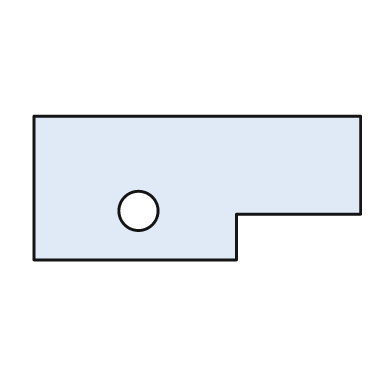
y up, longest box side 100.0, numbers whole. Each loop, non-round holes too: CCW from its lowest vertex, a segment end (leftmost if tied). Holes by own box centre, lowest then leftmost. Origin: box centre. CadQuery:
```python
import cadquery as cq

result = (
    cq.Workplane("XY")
    .moveTo(-50.0, -22.0)
    .lineTo(12.0, -22.0)
    .lineTo(12.0, -8.0)
    .lineTo(50.0, -8.0)
    .lineTo(50.0, 22.0)
    .lineTo(-50.0, 22.0)
    .close()
    .moveTo(-18.0, -7.0)
    .circle(6.0)
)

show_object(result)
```